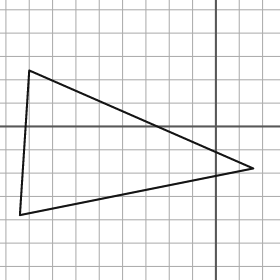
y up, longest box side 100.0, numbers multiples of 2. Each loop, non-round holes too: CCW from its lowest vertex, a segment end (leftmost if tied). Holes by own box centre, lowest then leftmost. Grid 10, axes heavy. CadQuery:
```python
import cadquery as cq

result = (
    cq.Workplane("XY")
    .moveTo(-84.0, -38.0)
    .lineTo(16.0, -18.0)
    .lineTo(-80.0, 24.0)
    .close()
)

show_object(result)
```